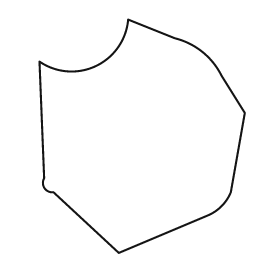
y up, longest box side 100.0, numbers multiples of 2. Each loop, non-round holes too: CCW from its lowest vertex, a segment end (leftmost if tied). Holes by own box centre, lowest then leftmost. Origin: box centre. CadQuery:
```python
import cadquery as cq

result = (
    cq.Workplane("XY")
    .moveTo(-10.0, -50.0)
    .lineTo(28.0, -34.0)
    .threePointArc((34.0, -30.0), (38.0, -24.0))
    .lineTo(44.0, 10.0)
    .lineTo(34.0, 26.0)
    .threePointArc((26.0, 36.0), (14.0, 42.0))
    .lineTo(-6.0, 50.0)
    .threePointArc((-20.0, 30.0), (-44.0, 32.0))
    .lineTo(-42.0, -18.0)
    .threePointArc((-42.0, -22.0), (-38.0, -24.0))
    .close()
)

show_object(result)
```